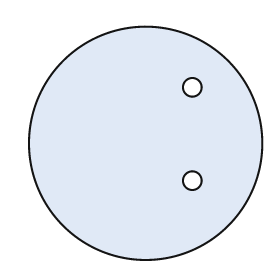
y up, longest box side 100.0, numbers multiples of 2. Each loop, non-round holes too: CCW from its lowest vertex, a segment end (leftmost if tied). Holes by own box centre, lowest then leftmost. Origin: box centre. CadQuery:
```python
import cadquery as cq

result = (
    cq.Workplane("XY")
    .moveTo(0.0, 0.0)
    .circle(50.0)
    .moveTo(20.0, -16.0)
    .circle(4.0)
    .moveTo(20.0, 24.0)
    .circle(4.0)
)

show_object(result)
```